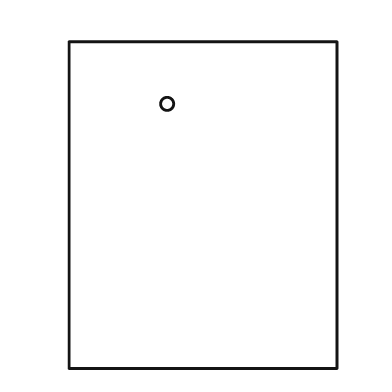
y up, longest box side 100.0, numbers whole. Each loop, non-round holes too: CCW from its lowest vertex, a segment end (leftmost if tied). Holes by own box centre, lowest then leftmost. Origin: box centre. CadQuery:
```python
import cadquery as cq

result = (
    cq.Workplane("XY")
    .moveTo(-41.0, -50.0)
    .lineTo(41.0, -50.0)
    .lineTo(41.0, 50.0)
    .lineTo(-41.0, 50.0)
    .close()
    .moveTo(-11.0, 31.0)
    .circle(2.0)
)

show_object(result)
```